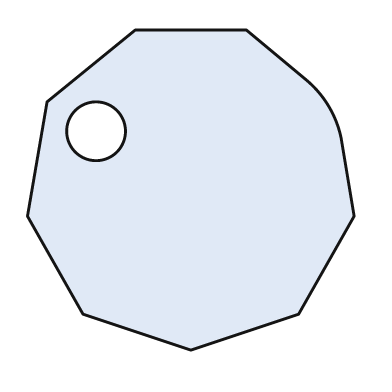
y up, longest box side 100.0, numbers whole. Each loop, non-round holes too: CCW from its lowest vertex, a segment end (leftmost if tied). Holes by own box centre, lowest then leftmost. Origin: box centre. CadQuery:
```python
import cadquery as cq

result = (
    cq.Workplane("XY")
    .moveTo(0.0, -49.0)
    .lineTo(33.0, -38.0)
    .lineTo(50.0, -8.0)
    .lineTo(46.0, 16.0)
    .threePointArc((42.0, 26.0), (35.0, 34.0))
    .lineTo(17.0, 49.0)
    .lineTo(-17.0, 49.0)
    .lineTo(-44.0, 27.0)
    .lineTo(-50.0, -8.0)
    .lineTo(-33.0, -38.0)
    .close()
    .moveTo(-29.0, 18.0)
    .circle(9.0)
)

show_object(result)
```